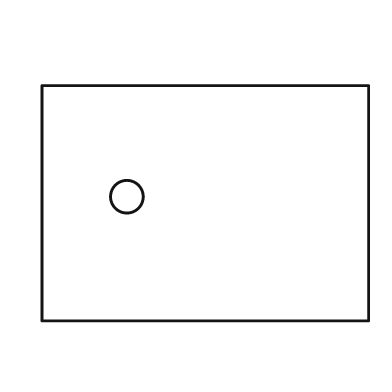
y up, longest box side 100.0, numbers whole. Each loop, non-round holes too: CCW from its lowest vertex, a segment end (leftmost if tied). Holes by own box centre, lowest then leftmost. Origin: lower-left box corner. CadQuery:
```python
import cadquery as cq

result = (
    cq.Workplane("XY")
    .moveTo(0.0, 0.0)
    .lineTo(100.0, 0.0)
    .lineTo(100.0, 72.0)
    .lineTo(0.0, 72.0)
    .close()
    .moveTo(26.0, 38.0)
    .circle(5.0)
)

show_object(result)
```